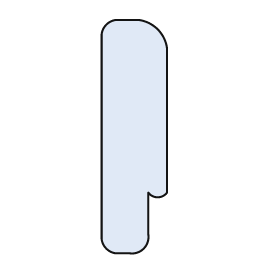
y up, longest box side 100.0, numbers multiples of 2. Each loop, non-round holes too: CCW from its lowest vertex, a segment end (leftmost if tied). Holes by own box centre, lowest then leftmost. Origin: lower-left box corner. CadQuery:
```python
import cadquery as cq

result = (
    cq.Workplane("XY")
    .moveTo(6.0, 0.0)
    .lineTo(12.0, 0.0)
    .threePointArc((18.0, 2.0), (20.0, 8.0))
    .lineTo(20.0, 26.0)
    .threePointArc((24.0, 24.0), (28.0, 26.0))
    .lineTo(28.0, 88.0)
    .threePointArc((24.0, 96.0), (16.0, 100.0))
    .lineTo(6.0, 100.0)
    .threePointArc((2.0, 98.0), (0.0, 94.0))
    .lineTo(0.0, 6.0)
    .threePointArc((2.0, 2.0), (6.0, 0.0))
    .close()
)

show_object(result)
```